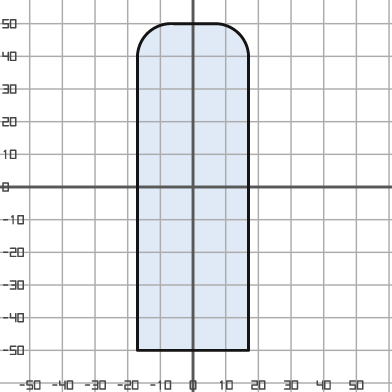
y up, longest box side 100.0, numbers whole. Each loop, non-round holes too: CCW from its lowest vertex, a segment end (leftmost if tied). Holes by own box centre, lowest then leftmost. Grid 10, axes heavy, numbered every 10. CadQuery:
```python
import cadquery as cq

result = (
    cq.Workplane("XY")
    .moveTo(-17.0, -50.0)
    .lineTo(17.0, -50.0)
    .lineTo(17.0, 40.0)
    .threePointArc((14.0, 47.0), (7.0, 50.0))
    .lineTo(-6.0, 50.0)
    .threePointArc((-14.0, 47.0), (-17.0, 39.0))
    .close()
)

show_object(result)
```